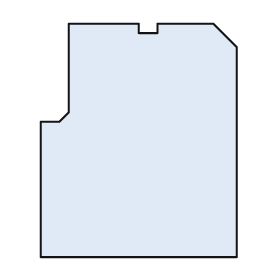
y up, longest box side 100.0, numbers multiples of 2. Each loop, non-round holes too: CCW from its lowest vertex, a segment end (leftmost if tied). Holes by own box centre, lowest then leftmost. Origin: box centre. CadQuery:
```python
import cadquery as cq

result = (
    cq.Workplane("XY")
    .moveTo(-42.0, -50.0)
    .lineTo(42.0, -50.0)
    .lineTo(42.0, 40.0)
    .lineTo(32.0, 50.0)
    .lineTo(8.0, 50.0)
    .lineTo(8.0, 46.0)
    .lineTo(0.0, 46.0)
    .lineTo(0.0, 50.0)
    .lineTo(-30.0, 50.0)
    .lineTo(-30.0, 12.0)
    .lineTo(-34.0, 8.0)
    .lineTo(-42.0, 8.0)
    .close()
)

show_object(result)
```